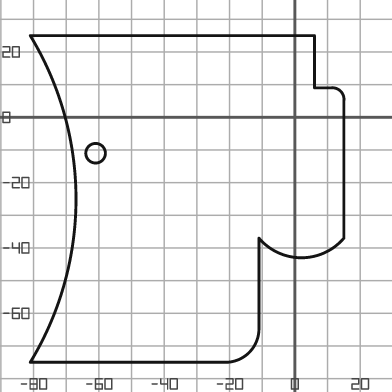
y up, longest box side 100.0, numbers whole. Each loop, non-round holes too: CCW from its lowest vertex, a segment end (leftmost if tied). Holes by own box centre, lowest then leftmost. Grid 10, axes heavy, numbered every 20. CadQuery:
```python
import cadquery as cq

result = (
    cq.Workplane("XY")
    .moveTo(-81.0, -75.0)
    .lineTo(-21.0, -75.0)
    .threePointArc((-14.0, -72.0), (-11.0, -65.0))
    .lineTo(-11.0, -37.0)
    .threePointArc((2.0, -43.0), (15.0, -37.0))
    .lineTo(15.0, 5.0)
    .threePointArc((14.0, 8.0), (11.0, 9.0))
    .lineTo(6.0, 9.0)
    .lineTo(6.0, 25.0)
    .lineTo(-81.0, 25.0)
    .threePointArc((-67.0, -25.0), (-81.0, -75.0))
    .close()
    .moveTo(-61.0, -11.0)
    .circle(3.0)
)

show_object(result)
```